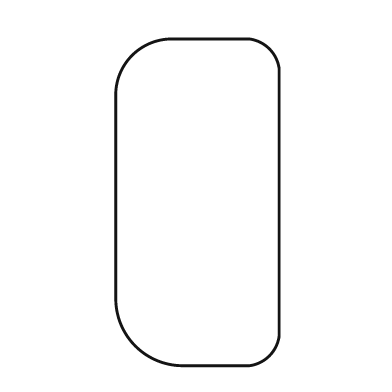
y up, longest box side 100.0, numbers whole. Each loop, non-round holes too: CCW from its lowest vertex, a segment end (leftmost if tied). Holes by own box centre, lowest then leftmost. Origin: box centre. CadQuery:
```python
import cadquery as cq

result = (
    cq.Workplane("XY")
    .moveTo(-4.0, -50.0)
    .lineTo(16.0, -50.0)
    .threePointArc((22.0, -47.0), (25.0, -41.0))
    .lineTo(25.0, 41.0)
    .threePointArc((22.0, 47.0), (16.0, 50.0))
    .lineTo(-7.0, 50.0)
    .threePointArc((-20.0, 45.0), (-25.0, 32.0))
    .lineTo(-25.0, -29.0)
    .threePointArc((-19.0, -44.0), (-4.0, -50.0))
    .close()
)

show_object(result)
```